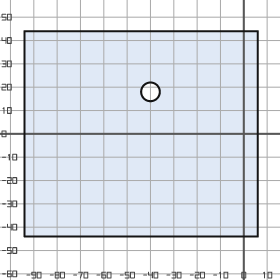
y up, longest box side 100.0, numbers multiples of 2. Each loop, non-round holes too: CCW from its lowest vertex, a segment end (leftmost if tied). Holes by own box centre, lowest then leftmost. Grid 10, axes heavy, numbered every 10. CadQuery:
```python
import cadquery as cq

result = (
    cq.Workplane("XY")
    .moveTo(-94.0, -44.0)
    .lineTo(6.0, -44.0)
    .lineTo(6.0, 44.0)
    .lineTo(-94.0, 44.0)
    .close()
    .moveTo(-40.0, 18.0)
    .circle(4.0)
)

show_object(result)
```